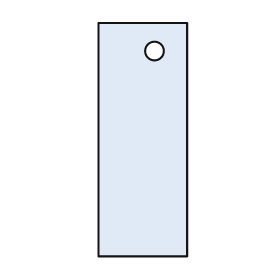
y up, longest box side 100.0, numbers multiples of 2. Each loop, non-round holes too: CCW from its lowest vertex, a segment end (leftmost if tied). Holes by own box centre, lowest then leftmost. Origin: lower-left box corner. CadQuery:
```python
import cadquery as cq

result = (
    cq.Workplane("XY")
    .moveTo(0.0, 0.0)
    .lineTo(38.0, 0.0)
    .lineTo(38.0, 100.0)
    .lineTo(0.0, 100.0)
    .close()
    .moveTo(24.0, 88.0)
    .circle(4.0)
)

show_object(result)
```